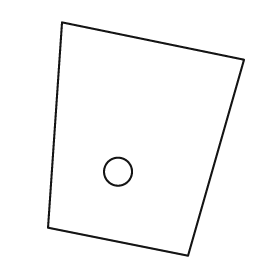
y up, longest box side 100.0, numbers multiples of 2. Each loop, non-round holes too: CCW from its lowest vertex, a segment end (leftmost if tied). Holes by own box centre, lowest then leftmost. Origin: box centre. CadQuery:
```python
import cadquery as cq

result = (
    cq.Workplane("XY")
    .moveTo(18.0, -50.0)
    .lineTo(42.0, 34.0)
    .lineTo(-36.0, 50.0)
    .lineTo(-42.0, -38.0)
    .close()
    .moveTo(-12.0, -14.0)
    .circle(6.0)
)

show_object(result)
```